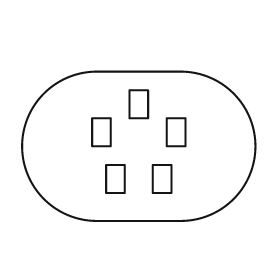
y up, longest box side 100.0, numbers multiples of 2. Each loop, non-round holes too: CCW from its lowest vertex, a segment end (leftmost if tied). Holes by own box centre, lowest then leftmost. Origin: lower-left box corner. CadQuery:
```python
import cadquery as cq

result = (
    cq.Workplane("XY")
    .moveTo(32.0, 0.0)
    .lineTo(68.0, 0.0)
    .threePointArc((100.0, 32.0), (68.0, 64.0))
    .lineTo(32.0, 64.0)
    .threePointArc((0.0, 32.0), (32.0, 0.0))
    .close()
    .moveTo(36.0, 12.0)
    .lineTo(44.0, 12.0)
    .lineTo(44.0, 24.0)
    .lineTo(36.0, 24.0)
    .close()
    .moveTo(56.0, 12.0)
    .lineTo(64.0, 12.0)
    .lineTo(64.0, 24.0)
    .lineTo(56.0, 24.0)
    .close()
    .moveTo(30.0, 32.0)
    .lineTo(38.0, 32.0)
    .lineTo(38.0, 44.0)
    .lineTo(30.0, 44.0)
    .close()
    .moveTo(62.0, 32.0)
    .lineTo(70.0, 32.0)
    .lineTo(70.0, 44.0)
    .lineTo(62.0, 44.0)
    .close()
    .moveTo(46.0, 44.0)
    .lineTo(54.0, 44.0)
    .lineTo(54.0, 56.0)
    .lineTo(46.0, 56.0)
    .close()
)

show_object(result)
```